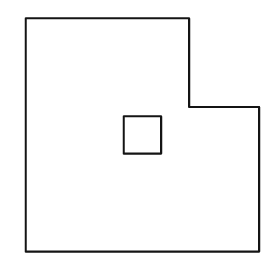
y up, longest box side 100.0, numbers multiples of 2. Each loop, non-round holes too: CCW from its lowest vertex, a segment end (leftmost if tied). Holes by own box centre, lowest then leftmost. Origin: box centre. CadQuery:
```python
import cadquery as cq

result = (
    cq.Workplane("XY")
    .moveTo(-50.0, -50.0)
    .lineTo(50.0, -50.0)
    .lineTo(50.0, 12.0)
    .lineTo(20.0, 12.0)
    .lineTo(20.0, 50.0)
    .lineTo(-50.0, 50.0)
    .close()
    .moveTo(-8.0, -8.0)
    .lineTo(8.0, -8.0)
    .lineTo(8.0, 8.0)
    .lineTo(-8.0, 8.0)
    .close()
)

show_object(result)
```